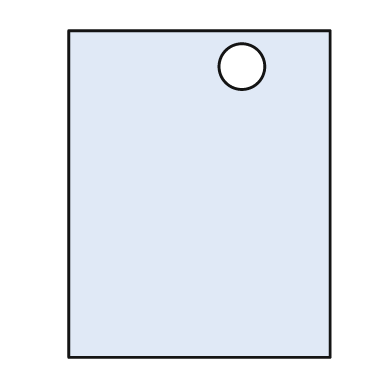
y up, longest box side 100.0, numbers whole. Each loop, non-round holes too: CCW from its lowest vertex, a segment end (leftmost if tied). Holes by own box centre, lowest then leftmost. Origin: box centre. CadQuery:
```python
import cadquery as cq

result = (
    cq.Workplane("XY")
    .moveTo(-40.0, -50.0)
    .lineTo(40.0, -50.0)
    .lineTo(40.0, 50.0)
    .lineTo(-40.0, 50.0)
    .close()
    .moveTo(13.0, 39.0)
    .circle(7.0)
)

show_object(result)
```